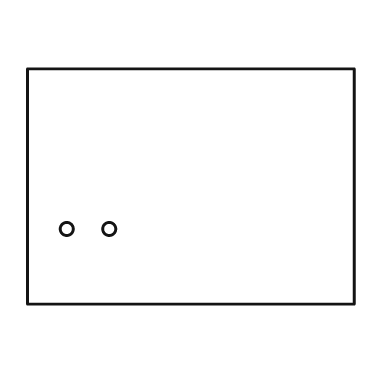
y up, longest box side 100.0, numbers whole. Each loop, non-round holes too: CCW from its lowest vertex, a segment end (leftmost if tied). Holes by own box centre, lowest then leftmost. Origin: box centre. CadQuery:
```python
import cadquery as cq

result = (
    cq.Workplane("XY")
    .moveTo(-50.0, -36.0)
    .lineTo(50.0, -36.0)
    .lineTo(50.0, 36.0)
    .lineTo(-50.0, 36.0)
    .close()
    .moveTo(-38.0, -13.0)
    .circle(2.0)
    .moveTo(-25.0, -13.0)
    .circle(2.0)
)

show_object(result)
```